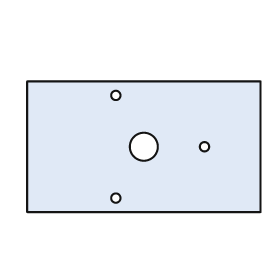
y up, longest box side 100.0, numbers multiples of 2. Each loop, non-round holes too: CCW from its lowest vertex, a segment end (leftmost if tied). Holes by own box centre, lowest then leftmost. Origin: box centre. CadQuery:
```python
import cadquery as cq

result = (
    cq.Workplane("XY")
    .moveTo(-50.0, -28.0)
    .lineTo(50.0, -28.0)
    .lineTo(50.0, 28.0)
    .lineTo(-50.0, 28.0)
    .close()
    .moveTo(-12.0, -22.0)
    .circle(2.0)
    .moveTo(0.0, 0.0)
    .circle(6.0)
    .moveTo(26.0, 0.0)
    .circle(2.0)
    .moveTo(-12.0, 22.0)
    .circle(2.0)
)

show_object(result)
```